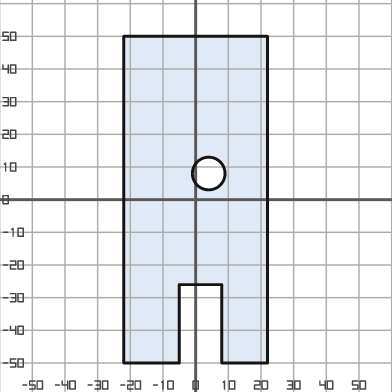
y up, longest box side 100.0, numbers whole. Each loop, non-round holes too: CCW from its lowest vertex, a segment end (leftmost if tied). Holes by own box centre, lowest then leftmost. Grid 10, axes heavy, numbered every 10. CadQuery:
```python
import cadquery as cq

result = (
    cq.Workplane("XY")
    .moveTo(-22.0, -50.0)
    .lineTo(-5.0, -50.0)
    .lineTo(-5.0, -26.0)
    .lineTo(8.0, -26.0)
    .lineTo(8.0, -50.0)
    .lineTo(22.0, -50.0)
    .lineTo(22.0, 50.0)
    .lineTo(-22.0, 50.0)
    .close()
    .moveTo(4.0, 8.0)
    .circle(5.0)
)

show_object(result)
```